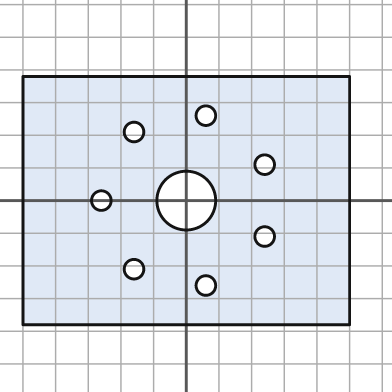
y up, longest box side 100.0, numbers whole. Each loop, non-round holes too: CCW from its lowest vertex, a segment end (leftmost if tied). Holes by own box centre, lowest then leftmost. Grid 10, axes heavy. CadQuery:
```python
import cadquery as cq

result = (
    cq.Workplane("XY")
    .moveTo(-50.0, -38.0)
    .lineTo(50.0, -38.0)
    .lineTo(50.0, 38.0)
    .lineTo(-50.0, 38.0)
    .close()
    .moveTo(6.0, -26.0)
    .circle(3.0)
    .moveTo(-16.0, -21.0)
    .circle(3.0)
    .moveTo(24.0, -11.0)
    .circle(3.0)
    .moveTo(-26.0, 0.0)
    .circle(3.0)
    .moveTo(0.0, 0.0)
    .circle(9.0)
    .moveTo(24.0, 11.0)
    .circle(3.0)
    .moveTo(-16.0, 21.0)
    .circle(3.0)
    .moveTo(6.0, 26.0)
    .circle(3.0)
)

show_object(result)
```